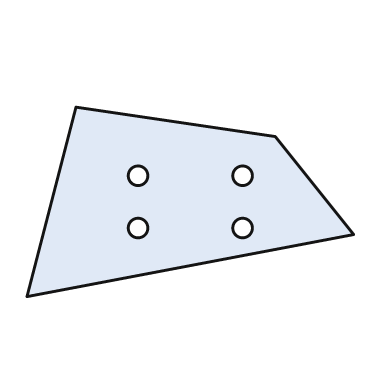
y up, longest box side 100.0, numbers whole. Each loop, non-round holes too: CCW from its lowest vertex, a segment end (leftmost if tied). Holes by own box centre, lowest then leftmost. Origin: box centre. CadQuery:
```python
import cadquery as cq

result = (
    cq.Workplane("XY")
    .moveTo(-50.0, -29.0)
    .lineTo(50.0, -10.0)
    .lineTo(26.0, 20.0)
    .lineTo(-35.0, 29.0)
    .close()
    .moveTo(-16.0, -8.0)
    .circle(3.0)
    .moveTo(16.0, -8.0)
    .circle(3.0)
    .moveTo(-16.0, 8.0)
    .circle(3.0)
    .moveTo(16.0, 8.0)
    .circle(3.0)
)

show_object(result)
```